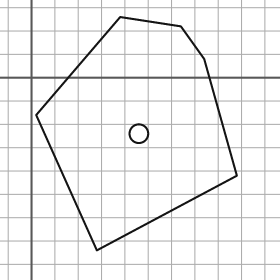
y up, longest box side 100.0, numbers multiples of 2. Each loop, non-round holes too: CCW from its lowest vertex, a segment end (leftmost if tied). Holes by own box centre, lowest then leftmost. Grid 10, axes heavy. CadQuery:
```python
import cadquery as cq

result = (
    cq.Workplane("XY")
    .moveTo(28.0, -74.0)
    .lineTo(88.0, -42.0)
    .lineTo(74.0, 8.0)
    .lineTo(64.0, 22.0)
    .lineTo(38.0, 26.0)
    .lineTo(2.0, -16.0)
    .close()
    .moveTo(46.0, -24.0)
    .circle(4.0)
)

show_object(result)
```